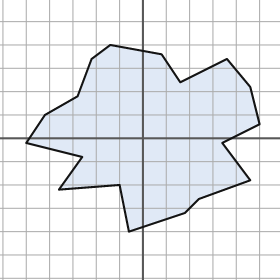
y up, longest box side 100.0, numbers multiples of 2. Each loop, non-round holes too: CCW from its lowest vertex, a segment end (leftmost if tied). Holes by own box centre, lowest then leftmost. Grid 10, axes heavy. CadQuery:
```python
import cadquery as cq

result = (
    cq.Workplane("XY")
    .moveTo(-6.0, -40.0)
    .lineTo(18.0, -32.0)
    .lineTo(24.0, -26.0)
    .lineTo(46.0, -18.0)
    .lineTo(34.0, -2.0)
    .lineTo(50.0, 6.0)
    .lineTo(46.0, 22.0)
    .lineTo(36.0, 34.0)
    .lineTo(16.0, 24.0)
    .lineTo(8.0, 36.0)
    .lineTo(-14.0, 40.0)
    .lineTo(-22.0, 34.0)
    .lineTo(-28.0, 18.0)
    .lineTo(-42.0, 10.0)
    .lineTo(-50.0, -2.0)
    .lineTo(-26.0, -8.0)
    .lineTo(-36.0, -22.0)
    .lineTo(-10.0, -20.0)
    .close()
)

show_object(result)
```